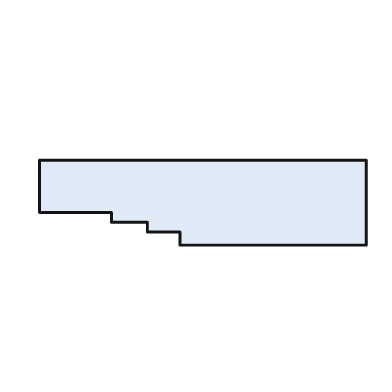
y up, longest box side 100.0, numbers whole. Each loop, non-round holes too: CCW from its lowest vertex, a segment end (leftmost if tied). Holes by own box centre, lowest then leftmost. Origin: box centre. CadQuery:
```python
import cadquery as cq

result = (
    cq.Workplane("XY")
    .moveTo(-7.0, -13.0)
    .lineTo(50.0, -13.0)
    .lineTo(50.0, 13.0)
    .lineTo(-50.0, 13.0)
    .lineTo(-50.0, -3.0)
    .lineTo(-28.0, -3.0)
    .lineTo(-28.0, -6.0)
    .lineTo(-17.0, -6.0)
    .lineTo(-17.0, -9.0)
    .lineTo(-7.0, -9.0)
    .close()
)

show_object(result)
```